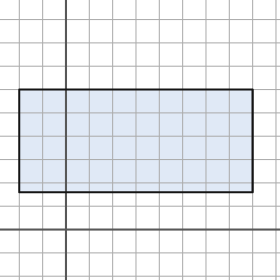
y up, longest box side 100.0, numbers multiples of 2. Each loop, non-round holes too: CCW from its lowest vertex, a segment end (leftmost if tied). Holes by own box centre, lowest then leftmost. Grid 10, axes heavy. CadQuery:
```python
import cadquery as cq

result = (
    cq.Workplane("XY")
    .moveTo(-20.0, 16.0)
    .lineTo(80.0, 16.0)
    .lineTo(80.0, 60.0)
    .lineTo(-20.0, 60.0)
    .close()
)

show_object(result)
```